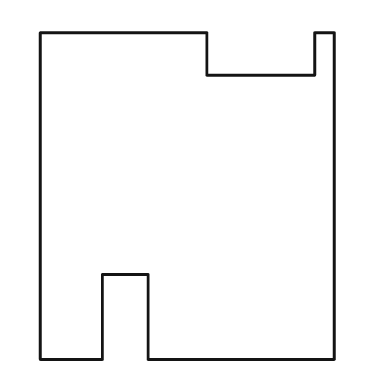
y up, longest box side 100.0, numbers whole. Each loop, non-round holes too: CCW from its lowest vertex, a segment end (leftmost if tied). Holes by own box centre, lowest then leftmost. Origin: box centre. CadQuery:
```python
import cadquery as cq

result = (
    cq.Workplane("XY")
    .moveTo(-45.0, -50.0)
    .lineTo(-26.0, -50.0)
    .lineTo(-26.0, -24.0)
    .lineTo(-12.0, -24.0)
    .lineTo(-12.0, -50.0)
    .lineTo(45.0, -50.0)
    .lineTo(45.0, 50.0)
    .lineTo(39.0, 50.0)
    .lineTo(39.0, 37.0)
    .lineTo(6.0, 37.0)
    .lineTo(6.0, 50.0)
    .lineTo(-45.0, 50.0)
    .close()
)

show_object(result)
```